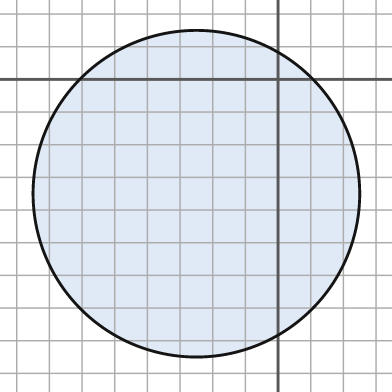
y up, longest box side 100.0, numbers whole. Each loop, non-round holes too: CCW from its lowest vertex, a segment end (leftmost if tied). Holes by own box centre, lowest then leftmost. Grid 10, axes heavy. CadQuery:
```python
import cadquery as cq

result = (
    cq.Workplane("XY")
    .moveTo(-25.0, -35.0)
    .circle(50.0)
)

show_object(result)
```